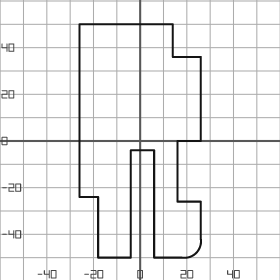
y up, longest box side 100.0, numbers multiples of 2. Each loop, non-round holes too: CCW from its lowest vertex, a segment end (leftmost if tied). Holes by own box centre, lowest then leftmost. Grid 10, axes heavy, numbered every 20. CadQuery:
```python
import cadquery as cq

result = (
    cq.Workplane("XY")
    .moveTo(-18.0, -50.0)
    .lineTo(-4.0, -50.0)
    .lineTo(-4.0, -4.0)
    .lineTo(6.0, -4.0)
    .lineTo(6.0, -50.0)
    .lineTo(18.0, -50.0)
    .threePointArc((24.0, -48.0), (26.0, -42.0))
    .lineTo(26.0, -26.0)
    .lineTo(16.0, -26.0)
    .lineTo(16.0, 0.0)
    .lineTo(26.0, 0.0)
    .lineTo(26.0, 36.0)
    .lineTo(14.0, 36.0)
    .lineTo(14.0, 50.0)
    .lineTo(-26.0, 50.0)
    .lineTo(-26.0, -24.0)
    .lineTo(-18.0, -24.0)
    .close()
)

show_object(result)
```